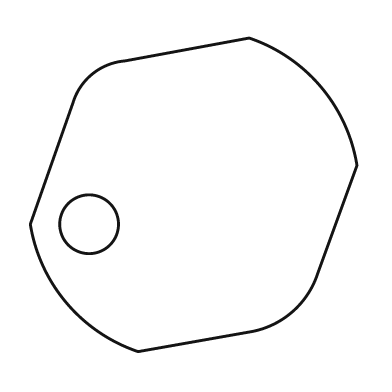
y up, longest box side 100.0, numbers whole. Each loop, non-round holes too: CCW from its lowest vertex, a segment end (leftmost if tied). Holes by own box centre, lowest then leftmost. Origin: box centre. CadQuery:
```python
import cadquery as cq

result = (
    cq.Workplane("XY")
    .moveTo(-17.0, -48.0)
    .lineTo(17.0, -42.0)
    .threePointArc((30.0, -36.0), (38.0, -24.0))
    .lineTo(50.0, 9.0)
    .threePointArc((39.0, 33.0), (17.0, 48.0))
    .lineTo(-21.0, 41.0)
    .threePointArc((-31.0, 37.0), (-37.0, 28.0))
    .lineTo(-50.0, -9.0)
    .threePointArc((-39.0, -33.0), (-17.0, -48.0))
    .close()
    .moveTo(-32.0, -9.0)
    .circle(9.0)
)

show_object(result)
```